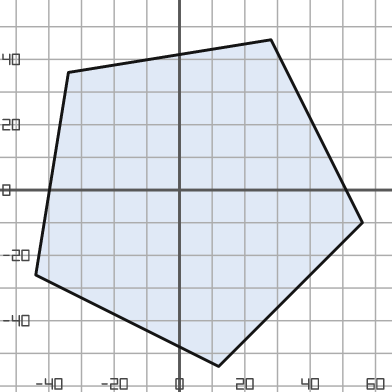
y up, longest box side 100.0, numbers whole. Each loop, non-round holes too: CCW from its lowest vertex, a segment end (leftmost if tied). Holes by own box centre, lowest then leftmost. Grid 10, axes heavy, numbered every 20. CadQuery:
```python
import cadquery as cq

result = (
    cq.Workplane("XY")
    .moveTo(12.0, -54.0)
    .lineTo(56.0, -10.0)
    .lineTo(28.0, 46.0)
    .lineTo(-34.0, 36.0)
    .lineTo(-44.0, -26.0)
    .close()
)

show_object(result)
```